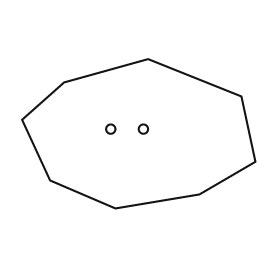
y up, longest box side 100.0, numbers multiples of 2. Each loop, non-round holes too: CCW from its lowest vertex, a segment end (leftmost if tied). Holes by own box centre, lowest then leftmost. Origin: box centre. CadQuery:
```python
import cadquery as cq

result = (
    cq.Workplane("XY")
    .moveTo(-10.0, -32.0)
    .lineTo(26.0, -26.0)
    .lineTo(50.0, -12.0)
    .lineTo(44.0, 16.0)
    .lineTo(4.0, 32.0)
    .lineTo(-32.0, 22.0)
    .lineTo(-50.0, 6.0)
    .lineTo(-38.0, -20.0)
    .close()
    .moveTo(-12.0, 2.0)
    .circle(2.0)
    .moveTo(2.0, 2.0)
    .circle(2.0)
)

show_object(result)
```